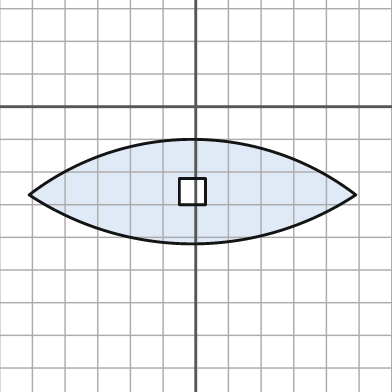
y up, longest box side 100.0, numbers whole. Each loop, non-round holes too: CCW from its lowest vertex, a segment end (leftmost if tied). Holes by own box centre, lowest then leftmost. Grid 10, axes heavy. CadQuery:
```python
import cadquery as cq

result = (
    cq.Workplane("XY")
    .moveTo(-51.0, -27.0)
    .threePointArc((-1.0, -42.0), (49.0, -27.0))
    .threePointArc((-1.0, -10.0), (-51.0, -27.0))
    .close()
    .moveTo(-5.0, -30.0)
    .lineTo(3.0, -30.0)
    .lineTo(3.0, -22.0)
    .lineTo(-5.0, -22.0)
    .close()
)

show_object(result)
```